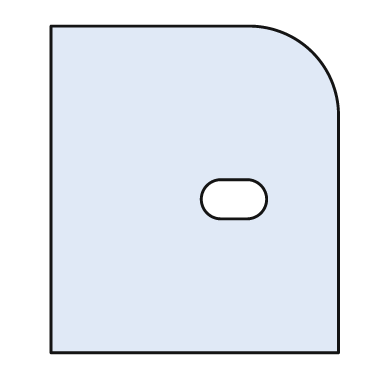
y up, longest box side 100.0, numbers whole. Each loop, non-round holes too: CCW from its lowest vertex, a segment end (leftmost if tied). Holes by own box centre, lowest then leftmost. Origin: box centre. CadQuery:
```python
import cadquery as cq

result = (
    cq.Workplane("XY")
    .moveTo(-44.0, -50.0)
    .lineTo(44.0, -50.0)
    .lineTo(44.0, 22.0)
    .threePointArc((36.0, 42.0), (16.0, 50.0))
    .lineTo(-44.0, 50.0)
    .close()
    .moveTo(8.0, -9.0)
    .lineTo(16.0, -9.0)
    .threePointArc((22.0, -3.0), (16.0, 3.0))
    .lineTo(8.0, 3.0)
    .threePointArc((2.0, -3.0), (8.0, -9.0))
    .close()
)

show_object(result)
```